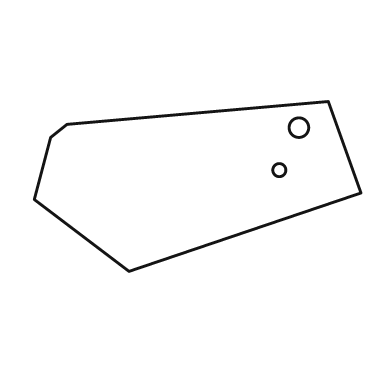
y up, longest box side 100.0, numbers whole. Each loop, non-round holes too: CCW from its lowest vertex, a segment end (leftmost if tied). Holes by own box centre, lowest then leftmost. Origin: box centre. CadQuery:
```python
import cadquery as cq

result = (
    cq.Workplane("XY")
    .moveTo(-21.0, -26.0)
    .lineTo(50.0, -2.0)
    .lineTo(40.0, 26.0)
    .lineTo(-40.0, 19.0)
    .lineTo(-45.0, 15.0)
    .lineTo(-50.0, -4.0)
    .close()
    .moveTo(25.0, 5.0)
    .circle(2.0)
    .moveTo(31.0, 18.0)
    .circle(3.0)
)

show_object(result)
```